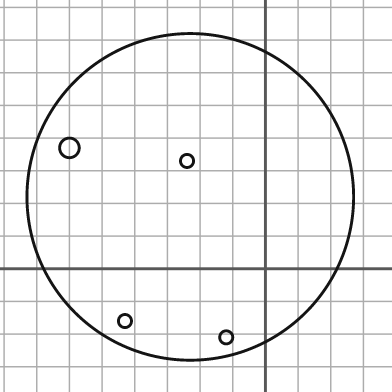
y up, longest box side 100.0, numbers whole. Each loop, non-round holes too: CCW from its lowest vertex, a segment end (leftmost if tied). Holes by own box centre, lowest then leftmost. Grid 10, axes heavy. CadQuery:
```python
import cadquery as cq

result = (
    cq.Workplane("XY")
    .moveTo(-23.0, 22.0)
    .circle(50.0)
    .moveTo(-12.0, -21.0)
    .circle(2.0)
    .moveTo(-43.0, -16.0)
    .circle(2.0)
    .moveTo(-24.0, 33.0)
    .circle(2.0)
    .moveTo(-60.0, 37.0)
    .circle(3.0)
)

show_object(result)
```